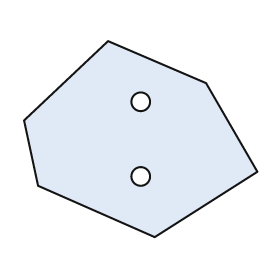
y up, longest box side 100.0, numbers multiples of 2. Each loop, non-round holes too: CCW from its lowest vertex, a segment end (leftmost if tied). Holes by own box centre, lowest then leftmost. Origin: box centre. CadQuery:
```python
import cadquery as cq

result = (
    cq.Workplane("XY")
    .moveTo(6.0, -42.0)
    .lineTo(50.0, -14.0)
    .lineTo(28.0, 24.0)
    .lineTo(-14.0, 42.0)
    .lineTo(-50.0, 8.0)
    .lineTo(-44.0, -20.0)
    .close()
    .moveTo(0.0, -16.0)
    .circle(4.0)
    .moveTo(0.0, 16.0)
    .circle(4.0)
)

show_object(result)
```